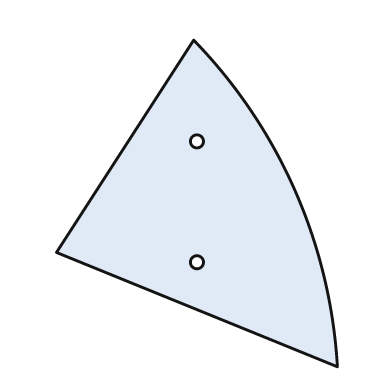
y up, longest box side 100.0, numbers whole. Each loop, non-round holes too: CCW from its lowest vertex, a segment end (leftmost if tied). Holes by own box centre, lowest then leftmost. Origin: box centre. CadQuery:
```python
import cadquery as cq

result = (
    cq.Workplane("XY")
    .moveTo(43.0, -50.0)
    .threePointArc((30.0, 4.0), (-1.0, 50.0))
    .lineTo(-43.0, -15.0)
    .close()
    .moveTo(0.0, -18.0)
    .circle(2.0)
    .moveTo(0.0, 19.0)
    .circle(2.0)
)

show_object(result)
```